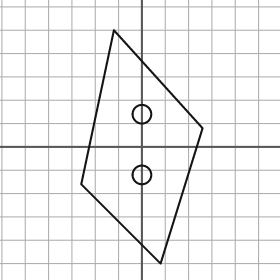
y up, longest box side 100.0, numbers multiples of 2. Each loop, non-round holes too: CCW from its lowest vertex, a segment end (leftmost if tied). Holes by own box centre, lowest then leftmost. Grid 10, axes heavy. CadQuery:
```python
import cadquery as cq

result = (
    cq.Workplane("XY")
    .moveTo(8.0, -50.0)
    .lineTo(26.0, 8.0)
    .lineTo(-12.0, 50.0)
    .lineTo(-26.0, -16.0)
    .close()
    .moveTo(0.0, -12.0)
    .circle(4.0)
    .moveTo(0.0, 14.0)
    .circle(4.0)
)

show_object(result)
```